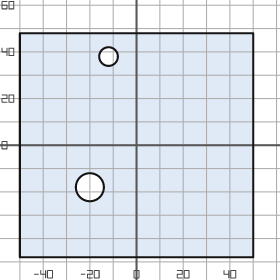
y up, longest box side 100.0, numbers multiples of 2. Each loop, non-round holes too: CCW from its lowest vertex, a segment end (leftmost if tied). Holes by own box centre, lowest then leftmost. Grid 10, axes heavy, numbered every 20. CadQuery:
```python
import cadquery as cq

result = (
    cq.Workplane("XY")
    .moveTo(-50.0, -48.0)
    .lineTo(50.0, -48.0)
    .lineTo(50.0, 48.0)
    .lineTo(-50.0, 48.0)
    .close()
    .moveTo(-20.0, -18.0)
    .circle(6.0)
    .moveTo(-12.0, 38.0)
    .circle(4.0)
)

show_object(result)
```